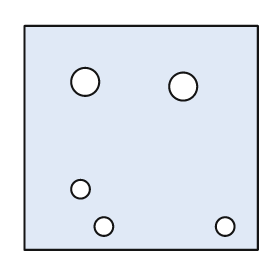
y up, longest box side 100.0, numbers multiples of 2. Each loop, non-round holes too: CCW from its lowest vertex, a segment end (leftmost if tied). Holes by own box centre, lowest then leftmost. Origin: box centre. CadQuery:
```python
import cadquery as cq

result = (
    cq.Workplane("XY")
    .moveTo(-50.0, -48.0)
    .lineTo(50.0, -48.0)
    .lineTo(50.0, 48.0)
    .lineTo(-50.0, 48.0)
    .close()
    .moveTo(-16.0, -38.0)
    .circle(4.0)
    .moveTo(36.0, -38.0)
    .circle(4.0)
    .moveTo(-26.0, -22.0)
    .circle(4.0)
    .moveTo(18.0, 22.0)
    .circle(6.0)
    .moveTo(-24.0, 24.0)
    .circle(6.0)
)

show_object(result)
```